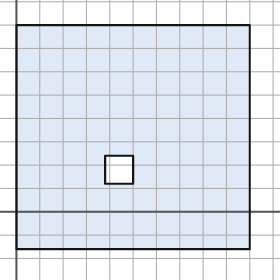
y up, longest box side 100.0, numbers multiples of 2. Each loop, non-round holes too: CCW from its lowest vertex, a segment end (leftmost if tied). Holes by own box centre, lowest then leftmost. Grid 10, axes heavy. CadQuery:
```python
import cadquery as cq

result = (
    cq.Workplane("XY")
    .moveTo(0.0, -16.0)
    .lineTo(100.0, -16.0)
    .lineTo(100.0, 80.0)
    .lineTo(0.0, 80.0)
    .close()
    .moveTo(38.0, 12.0)
    .lineTo(50.0, 12.0)
    .lineTo(50.0, 24.0)
    .lineTo(38.0, 24.0)
    .close()
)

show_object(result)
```